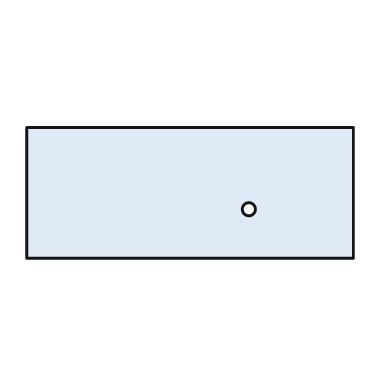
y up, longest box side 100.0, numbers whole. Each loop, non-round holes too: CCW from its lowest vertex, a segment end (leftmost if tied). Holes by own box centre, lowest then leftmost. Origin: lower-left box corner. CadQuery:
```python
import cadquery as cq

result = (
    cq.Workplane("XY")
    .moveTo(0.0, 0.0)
    .lineTo(100.0, 0.0)
    .lineTo(100.0, 40.0)
    .lineTo(0.0, 40.0)
    .close()
    .moveTo(68.0, 15.0)
    .circle(2.0)
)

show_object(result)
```